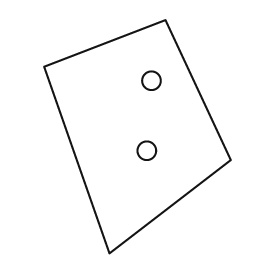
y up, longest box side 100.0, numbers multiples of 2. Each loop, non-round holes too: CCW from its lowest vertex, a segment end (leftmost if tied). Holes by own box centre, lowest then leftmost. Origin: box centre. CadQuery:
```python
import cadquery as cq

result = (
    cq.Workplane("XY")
    .moveTo(-12.0, -50.0)
    .lineTo(40.0, -10.0)
    .lineTo(12.0, 50.0)
    .lineTo(-40.0, 30.0)
    .close()
    .moveTo(4.0, -6.0)
    .circle(4.0)
    .moveTo(6.0, 24.0)
    .circle(4.0)
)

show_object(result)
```